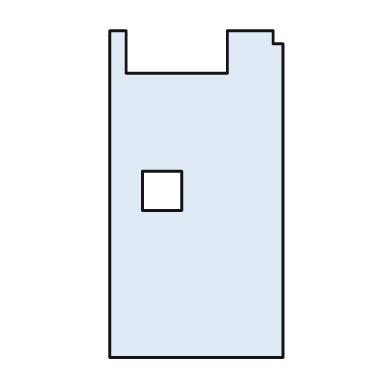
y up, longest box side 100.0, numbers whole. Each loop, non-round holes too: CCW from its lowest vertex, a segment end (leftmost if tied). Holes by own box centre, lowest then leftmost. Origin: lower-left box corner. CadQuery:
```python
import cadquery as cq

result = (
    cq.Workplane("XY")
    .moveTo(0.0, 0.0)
    .lineTo(53.0, 0.0)
    .lineTo(53.0, 96.0)
    .lineTo(50.0, 96.0)
    .lineTo(50.0, 100.0)
    .lineTo(36.0, 100.0)
    .lineTo(36.0, 87.0)
    .lineTo(5.0, 87.0)
    .lineTo(5.0, 100.0)
    .lineTo(0.0, 100.0)
    .close()
    .moveTo(10.0, 45.0)
    .lineTo(22.0, 45.0)
    .lineTo(22.0, 57.0)
    .lineTo(10.0, 57.0)
    .close()
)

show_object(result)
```